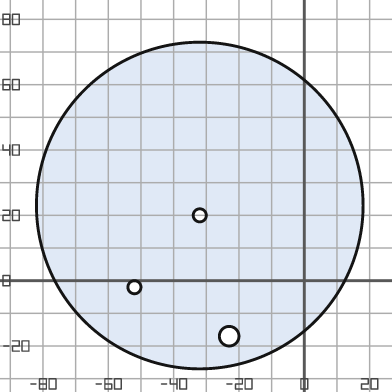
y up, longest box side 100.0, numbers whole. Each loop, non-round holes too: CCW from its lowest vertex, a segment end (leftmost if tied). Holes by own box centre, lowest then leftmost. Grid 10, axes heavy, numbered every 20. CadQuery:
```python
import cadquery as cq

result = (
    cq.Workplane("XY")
    .moveTo(-32.0, 23.0)
    .circle(50.0)
    .moveTo(-23.0, -17.0)
    .circle(3.0)
    .moveTo(-52.0, -2.0)
    .circle(2.0)
    .moveTo(-32.0, 20.0)
    .circle(2.0)
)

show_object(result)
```